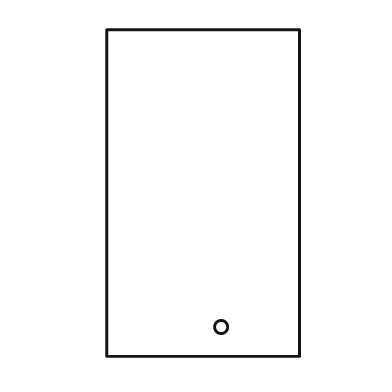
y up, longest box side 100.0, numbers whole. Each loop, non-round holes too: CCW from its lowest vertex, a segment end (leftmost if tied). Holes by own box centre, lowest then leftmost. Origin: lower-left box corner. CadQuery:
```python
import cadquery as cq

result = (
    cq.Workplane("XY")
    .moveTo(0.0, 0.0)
    .lineTo(59.0, 0.0)
    .lineTo(59.0, 100.0)
    .lineTo(0.0, 100.0)
    .close()
    .moveTo(35.0, 9.0)
    .circle(2.0)
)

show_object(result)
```